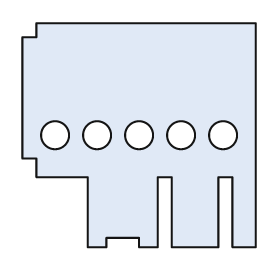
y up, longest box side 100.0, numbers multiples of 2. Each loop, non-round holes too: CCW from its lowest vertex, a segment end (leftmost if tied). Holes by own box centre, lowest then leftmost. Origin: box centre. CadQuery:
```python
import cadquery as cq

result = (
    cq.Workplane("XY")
    .moveTo(-22.0, -48.0)
    .lineTo(-14.0, -48.0)
    .lineTo(-14.0, -44.0)
    .lineTo(0.0, -44.0)
    .lineTo(0.0, -48.0)
    .lineTo(8.0, -48.0)
    .lineTo(8.0, -18.0)
    .lineTo(14.0, -18.0)
    .lineTo(14.0, -48.0)
    .lineTo(34.0, -48.0)
    .lineTo(34.0, -18.0)
    .lineTo(40.0, -18.0)
    .lineTo(40.0, -48.0)
    .lineTo(50.0, -48.0)
    .lineTo(50.0, 48.0)
    .lineTo(-44.0, 48.0)
    .lineTo(-44.0, 42.0)
    .lineTo(-50.0, 42.0)
    .lineTo(-50.0, -10.0)
    .lineTo(-44.0, -10.0)
    .lineTo(-44.0, -18.0)
    .lineTo(-22.0, -18.0)
    .close()
    .moveTo(-36.0, 0.0)
    .circle(6.0)
    .moveTo(-18.0, 0.0)
    .circle(6.0)
    .moveTo(0.0, 0.0)
    .circle(6.0)
    .moveTo(18.0, 0.0)
    .circle(6.0)
    .moveTo(36.0, 0.0)
    .circle(6.0)
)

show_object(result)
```